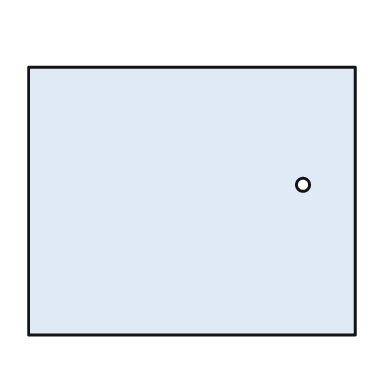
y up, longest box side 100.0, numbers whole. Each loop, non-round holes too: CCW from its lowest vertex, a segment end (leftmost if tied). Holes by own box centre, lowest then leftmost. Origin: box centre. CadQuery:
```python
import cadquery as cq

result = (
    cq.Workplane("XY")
    .moveTo(-50.0, -41.0)
    .lineTo(50.0, -41.0)
    .lineTo(50.0, 41.0)
    .lineTo(-50.0, 41.0)
    .close()
    .moveTo(34.0, 5.0)
    .circle(2.0)
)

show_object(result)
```